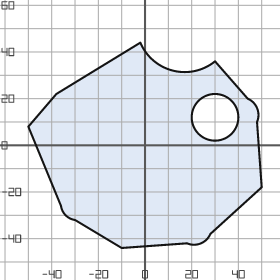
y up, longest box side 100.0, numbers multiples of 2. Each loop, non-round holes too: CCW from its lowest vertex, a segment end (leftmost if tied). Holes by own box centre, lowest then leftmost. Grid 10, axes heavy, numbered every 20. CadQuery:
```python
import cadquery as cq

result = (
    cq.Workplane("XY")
    .moveTo(-10.0, -44.0)
    .lineTo(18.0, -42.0)
    .threePointArc((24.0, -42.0), (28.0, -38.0))
    .lineTo(50.0, -18.0)
    .lineTo(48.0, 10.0)
    .threePointArc((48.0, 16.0), (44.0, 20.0))
    .lineTo(30.0, 36.0)
    .threePointArc((12.0, 32.0), (-2.0, 44.0))
    .lineTo(-38.0, 22.0)
    .lineTo(-50.0, 8.0)
    .lineTo(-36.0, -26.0)
    .threePointArc((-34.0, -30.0), (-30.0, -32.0))
    .close()
    .moveTo(30.0, 12.0)
    .circle(10.0)
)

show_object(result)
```